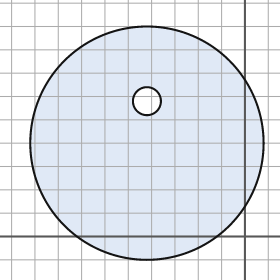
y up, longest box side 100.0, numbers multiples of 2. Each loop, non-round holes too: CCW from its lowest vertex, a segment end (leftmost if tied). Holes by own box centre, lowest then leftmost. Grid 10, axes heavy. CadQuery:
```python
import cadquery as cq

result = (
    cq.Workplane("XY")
    .moveTo(-42.0, 40.0)
    .circle(50.0)
    .moveTo(-42.0, 58.0)
    .circle(6.0)
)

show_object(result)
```